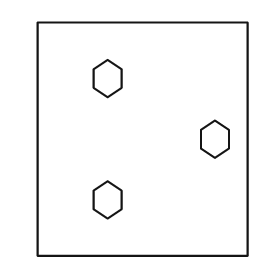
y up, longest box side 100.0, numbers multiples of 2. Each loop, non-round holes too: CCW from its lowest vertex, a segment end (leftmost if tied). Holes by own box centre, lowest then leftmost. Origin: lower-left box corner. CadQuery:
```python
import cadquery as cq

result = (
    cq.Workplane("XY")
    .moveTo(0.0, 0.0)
    .lineTo(90.0, 0.0)
    .lineTo(90.0, 100.0)
    .lineTo(0.0, 100.0)
    .close()
    .moveTo(30.0, 16.0)
    .lineTo(36.0, 20.0)
    .lineTo(36.0, 28.0)
    .lineTo(30.0, 32.0)
    .lineTo(24.0, 28.0)
    .lineTo(24.0, 20.0)
    .close()
    .moveTo(76.0, 42.0)
    .lineTo(82.0, 46.0)
    .lineTo(82.0, 54.0)
    .lineTo(76.0, 58.0)
    .lineTo(70.0, 54.0)
    .lineTo(70.0, 46.0)
    .close()
    .moveTo(30.0, 68.0)
    .lineTo(36.0, 72.0)
    .lineTo(36.0, 80.0)
    .lineTo(30.0, 84.0)
    .lineTo(24.0, 80.0)
    .lineTo(24.0, 72.0)
    .close()
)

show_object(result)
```